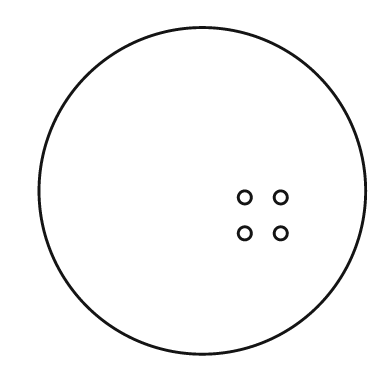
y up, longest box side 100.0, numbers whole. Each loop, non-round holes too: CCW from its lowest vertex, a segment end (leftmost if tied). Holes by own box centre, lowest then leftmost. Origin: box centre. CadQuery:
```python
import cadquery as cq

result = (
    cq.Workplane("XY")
    .moveTo(0.0, 0.0)
    .circle(50.0)
    .moveTo(13.0, -13.0)
    .circle(2.0)
    .moveTo(24.0, -13.0)
    .circle(2.0)
    .moveTo(13.0, -2.0)
    .circle(2.0)
    .moveTo(24.0, -2.0)
    .circle(2.0)
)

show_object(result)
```